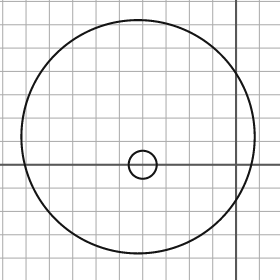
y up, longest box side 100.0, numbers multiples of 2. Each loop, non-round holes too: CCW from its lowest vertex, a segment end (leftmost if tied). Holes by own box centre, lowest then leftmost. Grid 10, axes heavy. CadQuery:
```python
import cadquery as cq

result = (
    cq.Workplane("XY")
    .moveTo(-42.0, 12.0)
    .circle(50.0)
    .moveTo(-40.0, 0.0)
    .circle(6.0)
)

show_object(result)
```